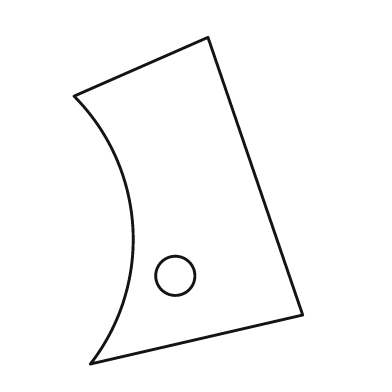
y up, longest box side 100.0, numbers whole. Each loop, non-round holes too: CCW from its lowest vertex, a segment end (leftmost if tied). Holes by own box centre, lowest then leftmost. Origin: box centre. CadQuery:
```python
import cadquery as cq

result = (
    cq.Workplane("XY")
    .moveTo(-30.0, -50.0)
    .lineTo(35.0, -35.0)
    .lineTo(6.0, 50.0)
    .lineTo(-35.0, 32.0)
    .threePointArc((-17.0, -8.0), (-30.0, -50.0))
    .close()
    .moveTo(-4.0, -23.0)
    .circle(6.0)
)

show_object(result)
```